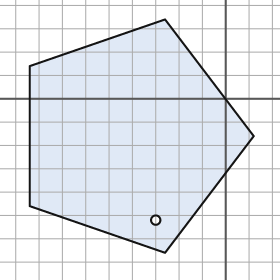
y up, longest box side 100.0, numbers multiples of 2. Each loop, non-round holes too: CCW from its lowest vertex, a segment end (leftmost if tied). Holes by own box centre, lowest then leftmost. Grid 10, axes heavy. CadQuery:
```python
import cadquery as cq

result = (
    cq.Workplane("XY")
    .moveTo(-26.0, -66.0)
    .lineTo(12.0, -16.0)
    .lineTo(-26.0, 34.0)
    .lineTo(-84.0, 14.0)
    .lineTo(-84.0, -46.0)
    .close()
    .moveTo(-30.0, -52.0)
    .circle(2.0)
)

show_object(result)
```